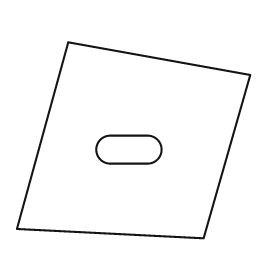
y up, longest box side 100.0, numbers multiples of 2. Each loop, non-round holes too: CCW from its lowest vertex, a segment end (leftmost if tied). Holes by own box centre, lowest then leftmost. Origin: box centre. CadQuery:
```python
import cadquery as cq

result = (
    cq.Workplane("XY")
    .moveTo(30.0, -42.0)
    .lineTo(50.0, 28.0)
    .lineTo(-28.0, 42.0)
    .lineTo(-50.0, -38.0)
    .close()
    .moveTo(-10.0, -10.0)
    .lineTo(6.0, -10.0)
    .threePointArc((12.0, -4.0), (6.0, 2.0))
    .lineTo(-10.0, 2.0)
    .threePointArc((-16.0, -4.0), (-10.0, -10.0))
    .close()
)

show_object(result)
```